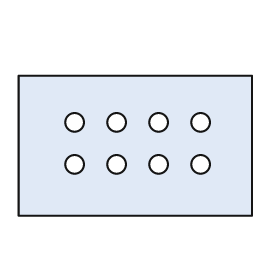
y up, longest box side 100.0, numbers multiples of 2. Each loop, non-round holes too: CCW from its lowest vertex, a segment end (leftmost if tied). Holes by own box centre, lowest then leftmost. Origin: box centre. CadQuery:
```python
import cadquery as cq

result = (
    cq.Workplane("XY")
    .moveTo(-50.0, -30.0)
    .lineTo(50.0, -30.0)
    .lineTo(50.0, 30.0)
    .lineTo(-50.0, 30.0)
    .close()
    .moveTo(-26.0, -8.0)
    .circle(4.0)
    .moveTo(-8.0, -8.0)
    .circle(4.0)
    .moveTo(10.0, -8.0)
    .circle(4.0)
    .moveTo(28.0, -8.0)
    .circle(4.0)
    .moveTo(-26.0, 10.0)
    .circle(4.0)
    .moveTo(-8.0, 10.0)
    .circle(4.0)
    .moveTo(10.0, 10.0)
    .circle(4.0)
    .moveTo(28.0, 10.0)
    .circle(4.0)
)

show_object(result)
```